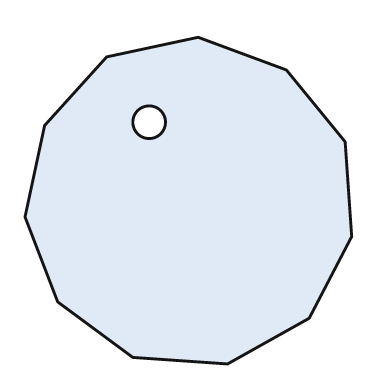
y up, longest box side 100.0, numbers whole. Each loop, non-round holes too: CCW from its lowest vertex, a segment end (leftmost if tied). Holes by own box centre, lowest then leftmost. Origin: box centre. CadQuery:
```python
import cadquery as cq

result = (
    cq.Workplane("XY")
    .moveTo(12.0, -50.0)
    .lineTo(37.0, -36.0)
    .lineTo(50.0, -11.0)
    .lineTo(48.0, 18.0)
    .lineTo(30.0, 40.0)
    .lineTo(3.0, 50.0)
    .lineTo(-25.0, 44.0)
    .lineTo(-44.0, 23.0)
    .lineTo(-50.0, -5.0)
    .lineTo(-40.0, -31.0)
    .lineTo(-17.0, -48.0)
    .close()
    .moveTo(-12.0, 24.0)
    .circle(5.0)
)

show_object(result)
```